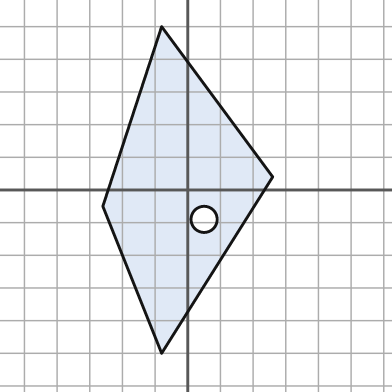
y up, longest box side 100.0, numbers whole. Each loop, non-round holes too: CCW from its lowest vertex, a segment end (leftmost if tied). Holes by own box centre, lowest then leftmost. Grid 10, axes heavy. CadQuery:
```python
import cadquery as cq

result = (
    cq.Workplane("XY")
    .moveTo(-8.0, -50.0)
    .lineTo(26.0, 4.0)
    .lineTo(-8.0, 50.0)
    .lineTo(-26.0, -5.0)
    .close()
    .moveTo(5.0, -9.0)
    .circle(4.0)
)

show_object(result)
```